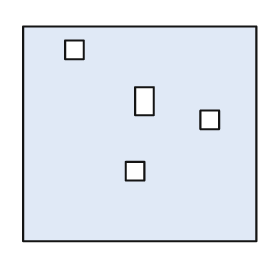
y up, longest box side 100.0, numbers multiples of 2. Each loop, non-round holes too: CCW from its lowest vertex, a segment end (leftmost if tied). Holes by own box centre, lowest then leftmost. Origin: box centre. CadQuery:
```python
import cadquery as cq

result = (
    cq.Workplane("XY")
    .moveTo(-50.0, -46.0)
    .lineTo(50.0, -46.0)
    .lineTo(50.0, 46.0)
    .lineTo(-50.0, 46.0)
    .close()
    .moveTo(-6.0, -20.0)
    .lineTo(2.0, -20.0)
    .lineTo(2.0, -12.0)
    .lineTo(-6.0, -12.0)
    .close()
    .moveTo(26.0, 2.0)
    .lineTo(34.0, 2.0)
    .lineTo(34.0, 10.0)
    .lineTo(26.0, 10.0)
    .close()
    .moveTo(-2.0, 8.0)
    .lineTo(6.0, 8.0)
    .lineTo(6.0, 20.0)
    .lineTo(-2.0, 20.0)
    .close()
    .moveTo(-32.0, 32.0)
    .lineTo(-24.0, 32.0)
    .lineTo(-24.0, 40.0)
    .lineTo(-32.0, 40.0)
    .close()
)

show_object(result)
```